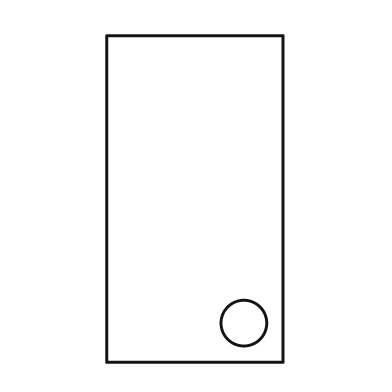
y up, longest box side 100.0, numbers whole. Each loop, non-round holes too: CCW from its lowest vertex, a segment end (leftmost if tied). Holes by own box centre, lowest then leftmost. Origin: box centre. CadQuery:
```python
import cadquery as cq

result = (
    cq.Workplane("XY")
    .moveTo(-27.0, -50.0)
    .lineTo(27.0, -50.0)
    .lineTo(27.0, 50.0)
    .lineTo(-27.0, 50.0)
    .close()
    .moveTo(15.0, -38.0)
    .circle(7.0)
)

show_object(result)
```